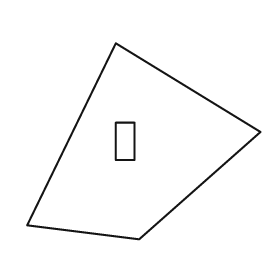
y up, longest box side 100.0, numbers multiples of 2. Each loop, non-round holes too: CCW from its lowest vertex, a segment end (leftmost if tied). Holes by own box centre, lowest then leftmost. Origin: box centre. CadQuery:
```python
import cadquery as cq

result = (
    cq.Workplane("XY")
    .moveTo(-2.0, -42.0)
    .lineTo(50.0, 4.0)
    .lineTo(-12.0, 42.0)
    .lineTo(-50.0, -36.0)
    .close()
    .moveTo(-12.0, -8.0)
    .lineTo(-4.0, -8.0)
    .lineTo(-4.0, 8.0)
    .lineTo(-12.0, 8.0)
    .close()
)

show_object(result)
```